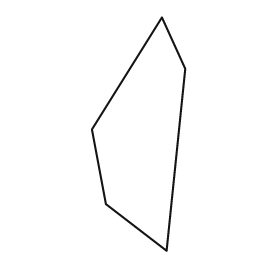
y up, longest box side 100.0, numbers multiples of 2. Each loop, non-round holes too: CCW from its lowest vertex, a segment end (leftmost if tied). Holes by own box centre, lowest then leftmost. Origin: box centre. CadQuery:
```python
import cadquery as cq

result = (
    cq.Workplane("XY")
    .moveTo(12.0, -50.0)
    .lineTo(20.0, 28.0)
    .lineTo(10.0, 50.0)
    .lineTo(-20.0, 2.0)
    .lineTo(-14.0, -30.0)
    .close()
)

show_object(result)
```